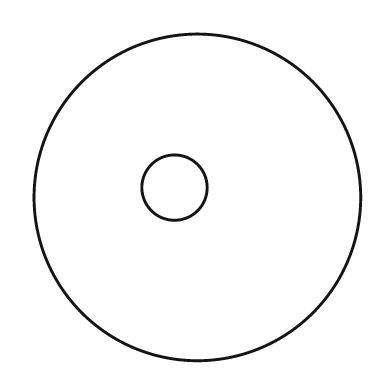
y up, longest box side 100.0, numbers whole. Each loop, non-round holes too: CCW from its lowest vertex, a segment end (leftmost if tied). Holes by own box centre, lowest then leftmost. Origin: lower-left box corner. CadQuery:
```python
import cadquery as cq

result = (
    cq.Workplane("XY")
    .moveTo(50.0, 50.0)
    .circle(50.0)
    .moveTo(43.0, 53.0)
    .circle(10.0)
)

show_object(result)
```